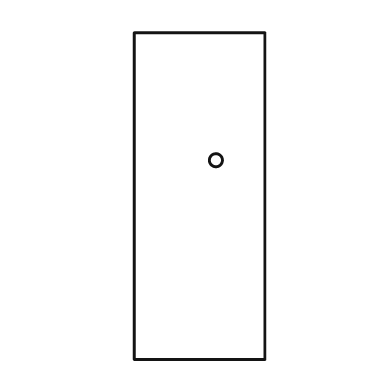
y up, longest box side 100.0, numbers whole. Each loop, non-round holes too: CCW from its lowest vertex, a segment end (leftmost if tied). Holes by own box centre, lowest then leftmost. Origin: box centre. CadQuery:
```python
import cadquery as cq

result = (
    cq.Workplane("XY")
    .moveTo(-20.0, -50.0)
    .lineTo(20.0, -50.0)
    .lineTo(20.0, 50.0)
    .lineTo(-20.0, 50.0)
    .close()
    .moveTo(5.0, 11.0)
    .circle(2.0)
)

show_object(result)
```